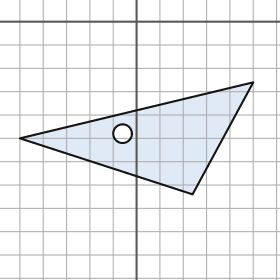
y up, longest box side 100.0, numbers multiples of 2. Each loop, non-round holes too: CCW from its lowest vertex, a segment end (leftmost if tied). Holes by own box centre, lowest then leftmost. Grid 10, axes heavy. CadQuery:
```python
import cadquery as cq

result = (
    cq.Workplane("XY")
    .moveTo(24.0, -74.0)
    .lineTo(50.0, -26.0)
    .lineTo(-50.0, -50.0)
    .close()
    .moveTo(-6.0, -48.0)
    .circle(4.0)
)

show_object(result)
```